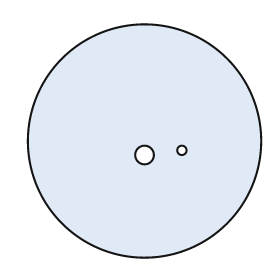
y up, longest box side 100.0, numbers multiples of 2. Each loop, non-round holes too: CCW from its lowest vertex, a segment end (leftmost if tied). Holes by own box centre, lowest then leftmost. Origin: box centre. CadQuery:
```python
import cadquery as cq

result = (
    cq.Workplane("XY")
    .moveTo(0.0, 0.0)
    .circle(50.0)
    .moveTo(0.0, -6.0)
    .circle(4.0)
    .moveTo(16.0, -4.0)
    .circle(2.0)
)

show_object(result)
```